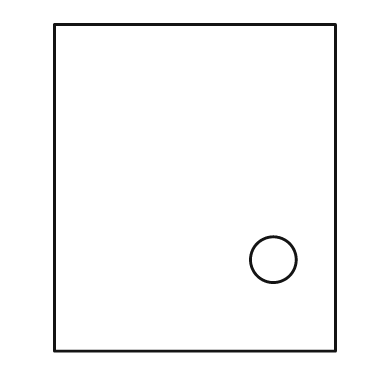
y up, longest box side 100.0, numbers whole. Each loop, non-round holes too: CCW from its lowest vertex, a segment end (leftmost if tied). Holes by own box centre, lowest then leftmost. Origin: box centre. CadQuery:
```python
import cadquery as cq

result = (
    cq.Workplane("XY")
    .moveTo(-43.0, -50.0)
    .lineTo(43.0, -50.0)
    .lineTo(43.0, 50.0)
    .lineTo(-43.0, 50.0)
    .close()
    .moveTo(24.0, -22.0)
    .circle(7.0)
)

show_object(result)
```